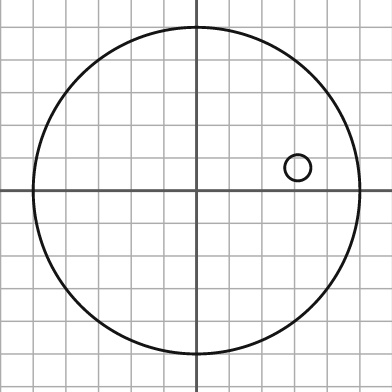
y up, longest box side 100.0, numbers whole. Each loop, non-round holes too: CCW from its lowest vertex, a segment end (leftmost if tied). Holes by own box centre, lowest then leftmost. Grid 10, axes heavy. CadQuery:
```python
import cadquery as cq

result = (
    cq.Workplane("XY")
    .moveTo(0.0, 0.0)
    .circle(50.0)
    .moveTo(31.0, 7.0)
    .circle(4.0)
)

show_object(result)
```